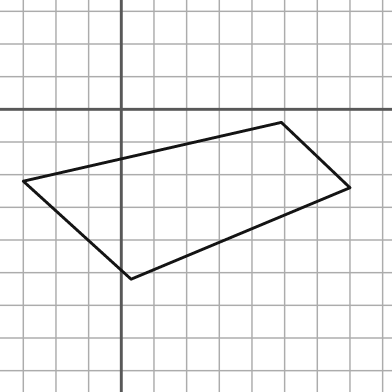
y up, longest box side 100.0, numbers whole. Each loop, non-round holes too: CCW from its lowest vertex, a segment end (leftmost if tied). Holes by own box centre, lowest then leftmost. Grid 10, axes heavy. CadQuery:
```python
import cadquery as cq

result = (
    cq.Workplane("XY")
    .moveTo(3.0, -52.0)
    .lineTo(70.0, -24.0)
    .lineTo(49.0, -4.0)
    .lineTo(-30.0, -22.0)
    .close()
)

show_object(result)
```